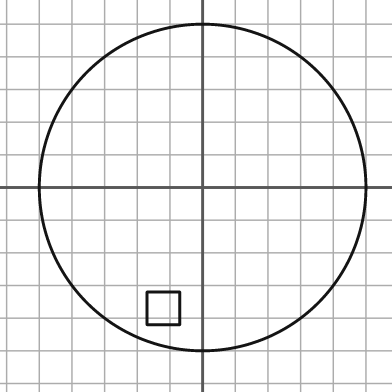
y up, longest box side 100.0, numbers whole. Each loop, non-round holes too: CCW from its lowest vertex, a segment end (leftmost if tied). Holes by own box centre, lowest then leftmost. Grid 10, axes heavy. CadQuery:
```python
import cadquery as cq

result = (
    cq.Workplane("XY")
    .moveTo(0.0, 0.0)
    .circle(50.0)
    .moveTo(-17.0, -42.0)
    .lineTo(-7.0, -42.0)
    .lineTo(-7.0, -32.0)
    .lineTo(-17.0, -32.0)
    .close()
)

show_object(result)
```